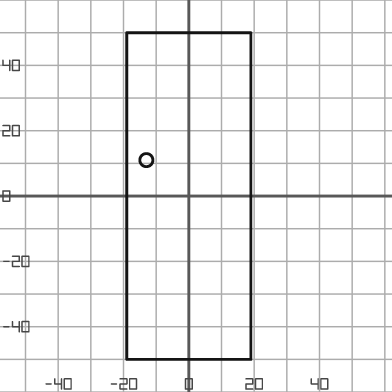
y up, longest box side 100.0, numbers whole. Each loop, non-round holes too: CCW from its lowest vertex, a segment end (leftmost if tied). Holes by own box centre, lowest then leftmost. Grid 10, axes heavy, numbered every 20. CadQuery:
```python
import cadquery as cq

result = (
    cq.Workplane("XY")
    .moveTo(-19.0, -50.0)
    .lineTo(19.0, -50.0)
    .lineTo(19.0, 50.0)
    .lineTo(-19.0, 50.0)
    .close()
    .moveTo(-13.0, 11.0)
    .circle(2.0)
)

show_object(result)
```